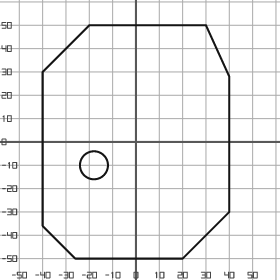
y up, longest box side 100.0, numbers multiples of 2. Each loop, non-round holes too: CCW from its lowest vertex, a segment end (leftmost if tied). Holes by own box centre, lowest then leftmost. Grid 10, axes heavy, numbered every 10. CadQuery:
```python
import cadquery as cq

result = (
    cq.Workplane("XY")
    .moveTo(-26.0, -50.0)
    .lineTo(20.0, -50.0)
    .lineTo(40.0, -30.0)
    .lineTo(40.0, 28.0)
    .lineTo(30.0, 50.0)
    .lineTo(-20.0, 50.0)
    .lineTo(-40.0, 30.0)
    .lineTo(-40.0, -36.0)
    .close()
    .moveTo(-18.0, -10.0)
    .circle(6.0)
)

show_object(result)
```